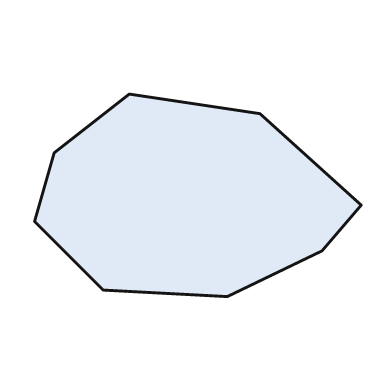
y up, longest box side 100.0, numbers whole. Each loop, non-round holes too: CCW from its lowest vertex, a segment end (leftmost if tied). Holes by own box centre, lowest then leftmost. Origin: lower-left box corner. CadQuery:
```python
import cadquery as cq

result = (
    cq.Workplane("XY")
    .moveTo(59.0, 0.0)
    .lineTo(88.0, 14.0)
    .lineTo(100.0, 28.0)
    .lineTo(69.0, 56.0)
    .lineTo(29.0, 62.0)
    .lineTo(6.0, 44.0)
    .lineTo(0.0, 23.0)
    .lineTo(21.0, 2.0)
    .close()
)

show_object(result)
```